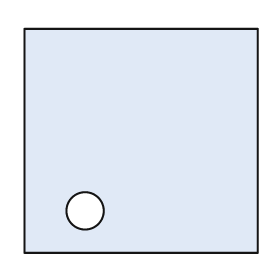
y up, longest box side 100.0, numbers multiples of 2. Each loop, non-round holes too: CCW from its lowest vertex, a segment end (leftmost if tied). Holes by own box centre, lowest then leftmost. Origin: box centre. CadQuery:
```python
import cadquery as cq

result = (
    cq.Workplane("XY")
    .moveTo(-50.0, -48.0)
    .lineTo(50.0, -48.0)
    .lineTo(50.0, 48.0)
    .lineTo(-50.0, 48.0)
    .close()
    .moveTo(-24.0, -30.0)
    .circle(8.0)
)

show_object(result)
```